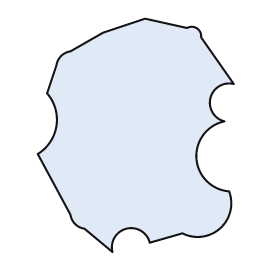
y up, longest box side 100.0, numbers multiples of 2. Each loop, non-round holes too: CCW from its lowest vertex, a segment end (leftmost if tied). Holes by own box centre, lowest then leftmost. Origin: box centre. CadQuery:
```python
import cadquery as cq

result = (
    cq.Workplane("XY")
    .moveTo(-10.0, -50.0)
    .threePointArc((-4.0, -40.0), (6.0, -46.0))
    .lineTo(20.0, -42.0)
    .threePointArc((36.0, -40.0), (40.0, -24.0))
    .threePointArc((26.0, -10.0), (38.0, 6.0))
    .threePointArc((32.0, 16.0), (42.0, 22.0))
    .lineTo(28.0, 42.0)
    .threePointArc((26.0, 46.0), (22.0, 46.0))
    .lineTo(4.0, 50.0)
    .lineTo(-14.0, 44.0)
    .lineTo(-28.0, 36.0)
    .threePointArc((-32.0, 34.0), (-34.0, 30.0))
    .lineTo(-38.0, 18.0)
    .threePointArc((-34.0, 4.0), (-42.0, -8.0))
    .lineTo(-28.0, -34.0)
    .threePointArc((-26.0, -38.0), (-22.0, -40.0))
    .close()
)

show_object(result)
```